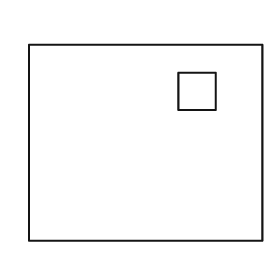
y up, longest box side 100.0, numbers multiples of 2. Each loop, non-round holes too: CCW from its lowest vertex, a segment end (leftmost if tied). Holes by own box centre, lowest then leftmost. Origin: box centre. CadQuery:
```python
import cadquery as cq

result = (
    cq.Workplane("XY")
    .moveTo(-50.0, -42.0)
    .lineTo(50.0, -42.0)
    .lineTo(50.0, 42.0)
    .lineTo(-50.0, 42.0)
    .close()
    .moveTo(14.0, 14.0)
    .lineTo(30.0, 14.0)
    .lineTo(30.0, 30.0)
    .lineTo(14.0, 30.0)
    .close()
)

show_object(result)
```